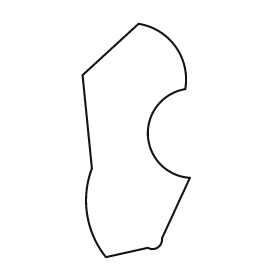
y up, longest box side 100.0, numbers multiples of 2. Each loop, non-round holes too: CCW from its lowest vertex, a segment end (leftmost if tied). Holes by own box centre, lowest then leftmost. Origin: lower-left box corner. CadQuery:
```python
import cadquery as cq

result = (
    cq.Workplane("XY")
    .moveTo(10.0, 0.0)
    .lineTo(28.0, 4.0)
    .threePointArc((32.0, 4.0), (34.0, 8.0))
    .lineTo(46.0, 34.0)
    .threePointArc((28.0, 52.0), (44.0, 72.0))
    .threePointArc((40.0, 90.0), (24.0, 100.0))
    .lineTo(0.0, 78.0)
    .lineTo(4.0, 38.0)
    .threePointArc((2.0, 18.0), (10.0, 0.0))
    .close()
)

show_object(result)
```